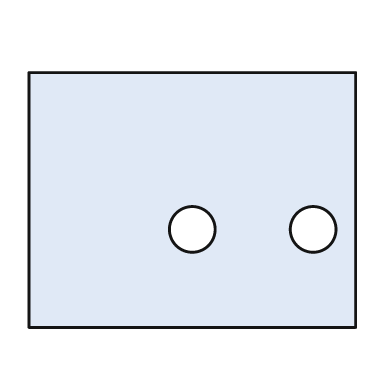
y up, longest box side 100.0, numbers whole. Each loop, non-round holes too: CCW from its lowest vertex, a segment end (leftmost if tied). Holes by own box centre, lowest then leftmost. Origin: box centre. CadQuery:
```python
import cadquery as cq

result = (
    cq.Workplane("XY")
    .moveTo(-50.0, -39.0)
    .lineTo(50.0, -39.0)
    .lineTo(50.0, 39.0)
    .lineTo(-50.0, 39.0)
    .close()
    .moveTo(0.0, -9.0)
    .circle(7.0)
    .moveTo(37.0, -9.0)
    .circle(7.0)
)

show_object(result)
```